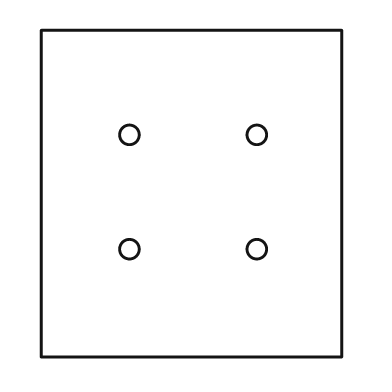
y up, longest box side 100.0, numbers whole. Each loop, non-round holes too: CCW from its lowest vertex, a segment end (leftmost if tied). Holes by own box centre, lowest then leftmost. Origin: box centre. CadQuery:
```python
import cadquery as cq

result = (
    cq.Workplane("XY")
    .moveTo(-46.0, -50.0)
    .lineTo(46.0, -50.0)
    .lineTo(46.0, 50.0)
    .lineTo(-46.0, 50.0)
    .close()
    .moveTo(-19.0, -17.0)
    .circle(3.0)
    .moveTo(20.0, -17.0)
    .circle(3.0)
    .moveTo(-19.0, 18.0)
    .circle(3.0)
    .moveTo(20.0, 18.0)
    .circle(3.0)
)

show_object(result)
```